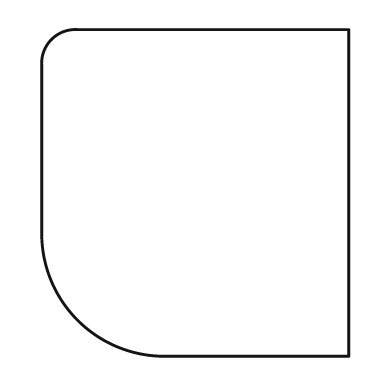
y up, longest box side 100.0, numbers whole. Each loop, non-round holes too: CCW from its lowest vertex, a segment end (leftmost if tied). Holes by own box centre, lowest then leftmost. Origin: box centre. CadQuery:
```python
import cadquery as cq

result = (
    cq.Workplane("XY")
    .moveTo(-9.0, -50.0)
    .lineTo(47.0, -50.0)
    .lineTo(47.0, 50.0)
    .lineTo(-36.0, 50.0)
    .threePointArc((-44.0, 47.0), (-47.0, 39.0))
    .lineTo(-47.0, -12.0)
    .threePointArc((-36.0, -39.0), (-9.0, -50.0))
    .close()
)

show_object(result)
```